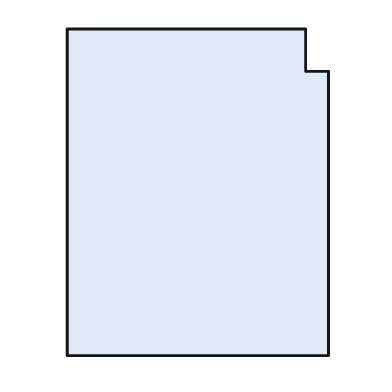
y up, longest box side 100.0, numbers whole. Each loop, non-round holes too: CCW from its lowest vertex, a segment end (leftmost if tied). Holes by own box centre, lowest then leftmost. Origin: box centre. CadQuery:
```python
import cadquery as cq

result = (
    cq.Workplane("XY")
    .moveTo(-40.0, -50.0)
    .lineTo(40.0, -50.0)
    .lineTo(40.0, 37.0)
    .lineTo(33.0, 37.0)
    .lineTo(33.0, 50.0)
    .lineTo(-40.0, 50.0)
    .close()
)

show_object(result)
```